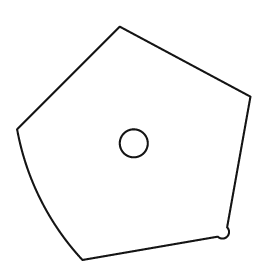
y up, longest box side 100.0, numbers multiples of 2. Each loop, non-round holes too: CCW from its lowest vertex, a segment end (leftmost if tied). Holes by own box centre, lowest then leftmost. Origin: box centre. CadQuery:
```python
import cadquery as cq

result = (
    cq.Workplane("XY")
    .moveTo(-22.0, -50.0)
    .lineTo(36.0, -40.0)
    .threePointArc((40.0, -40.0), (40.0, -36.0))
    .lineTo(50.0, 20.0)
    .lineTo(-6.0, 50.0)
    .lineTo(-50.0, 6.0)
    .threePointArc((-40.0, -24.0), (-22.0, -50.0))
    .close()
    .moveTo(0.0, 0.0)
    .circle(6.0)
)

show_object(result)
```